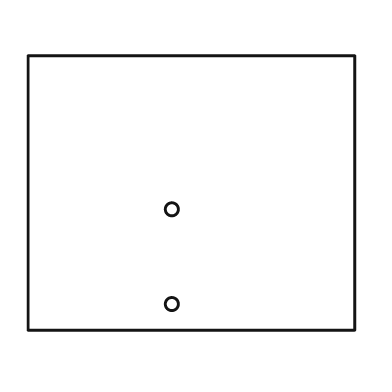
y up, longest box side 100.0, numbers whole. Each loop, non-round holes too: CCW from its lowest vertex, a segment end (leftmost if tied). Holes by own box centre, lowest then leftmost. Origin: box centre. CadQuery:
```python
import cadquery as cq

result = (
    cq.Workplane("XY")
    .moveTo(-50.0, -42.0)
    .lineTo(50.0, -42.0)
    .lineTo(50.0, 42.0)
    .lineTo(-50.0, 42.0)
    .close()
    .moveTo(-6.0, -34.0)
    .circle(2.0)
    .moveTo(-6.0, -5.0)
    .circle(2.0)
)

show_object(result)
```